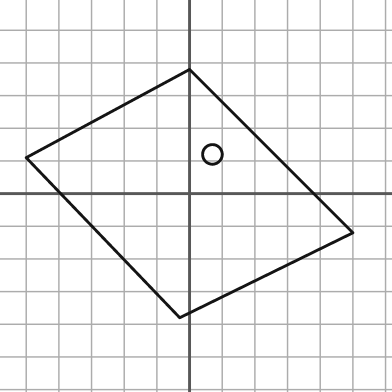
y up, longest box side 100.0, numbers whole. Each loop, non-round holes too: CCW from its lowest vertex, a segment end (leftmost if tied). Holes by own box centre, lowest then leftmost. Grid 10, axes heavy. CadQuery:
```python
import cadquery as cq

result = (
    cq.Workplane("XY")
    .moveTo(-3.0, -38.0)
    .lineTo(50.0, -12.0)
    .lineTo(0.0, 38.0)
    .lineTo(-50.0, 11.0)
    .close()
    .moveTo(7.0, 12.0)
    .circle(3.0)
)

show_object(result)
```